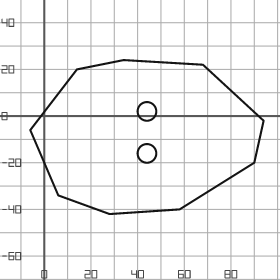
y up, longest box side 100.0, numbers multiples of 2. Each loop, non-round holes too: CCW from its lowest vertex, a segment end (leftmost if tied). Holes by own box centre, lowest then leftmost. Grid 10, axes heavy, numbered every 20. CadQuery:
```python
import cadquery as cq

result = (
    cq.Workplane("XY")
    .moveTo(28.0, -42.0)
    .lineTo(58.0, -40.0)
    .lineTo(90.0, -20.0)
    .lineTo(94.0, -2.0)
    .lineTo(68.0, 22.0)
    .lineTo(34.0, 24.0)
    .lineTo(14.0, 20.0)
    .lineTo(-6.0, -6.0)
    .lineTo(6.0, -34.0)
    .close()
    .moveTo(44.0, -16.0)
    .circle(4.0)
    .moveTo(44.0, 2.0)
    .circle(4.0)
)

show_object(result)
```